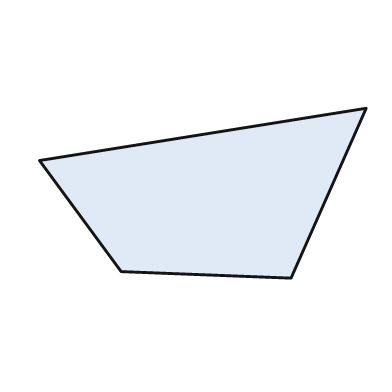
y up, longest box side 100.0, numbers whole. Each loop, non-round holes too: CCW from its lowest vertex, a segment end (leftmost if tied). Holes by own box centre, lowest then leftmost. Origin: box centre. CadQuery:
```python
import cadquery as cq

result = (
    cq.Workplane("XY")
    .moveTo(27.0, -26.0)
    .lineTo(50.0, 26.0)
    .lineTo(-50.0, 10.0)
    .lineTo(-25.0, -24.0)
    .close()
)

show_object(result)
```